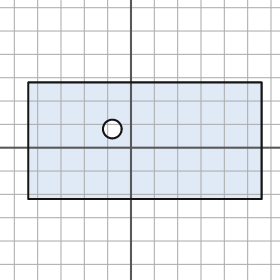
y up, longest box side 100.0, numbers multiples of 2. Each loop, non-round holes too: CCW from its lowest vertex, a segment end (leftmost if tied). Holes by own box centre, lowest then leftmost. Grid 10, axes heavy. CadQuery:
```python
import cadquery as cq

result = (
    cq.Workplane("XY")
    .moveTo(-44.0, -22.0)
    .lineTo(56.0, -22.0)
    .lineTo(56.0, 28.0)
    .lineTo(-44.0, 28.0)
    .close()
    .moveTo(-8.0, 8.0)
    .circle(4.0)
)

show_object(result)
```